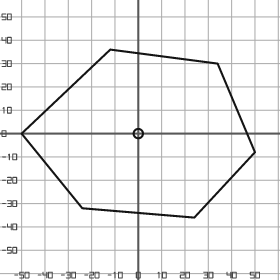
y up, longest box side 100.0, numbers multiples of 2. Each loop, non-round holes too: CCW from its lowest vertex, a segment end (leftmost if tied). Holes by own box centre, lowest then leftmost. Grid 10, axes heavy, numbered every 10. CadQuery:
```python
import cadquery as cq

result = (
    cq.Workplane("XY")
    .moveTo(24.0, -36.0)
    .lineTo(50.0, -8.0)
    .lineTo(34.0, 30.0)
    .lineTo(-12.0, 36.0)
    .lineTo(-50.0, 0.0)
    .lineTo(-24.0, -32.0)
    .close()
    .moveTo(0.0, 0.0)
    .circle(2.0)
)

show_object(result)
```